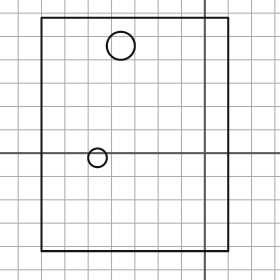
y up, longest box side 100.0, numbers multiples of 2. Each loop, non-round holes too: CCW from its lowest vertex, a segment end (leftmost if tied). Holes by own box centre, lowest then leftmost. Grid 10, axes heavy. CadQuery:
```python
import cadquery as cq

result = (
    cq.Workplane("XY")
    .moveTo(-70.0, -42.0)
    .lineTo(10.0, -42.0)
    .lineTo(10.0, 58.0)
    .lineTo(-70.0, 58.0)
    .close()
    .moveTo(-46.0, -2.0)
    .circle(4.0)
    .moveTo(-36.0, 46.0)
    .circle(6.0)
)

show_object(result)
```